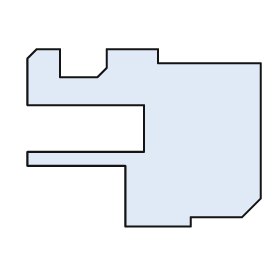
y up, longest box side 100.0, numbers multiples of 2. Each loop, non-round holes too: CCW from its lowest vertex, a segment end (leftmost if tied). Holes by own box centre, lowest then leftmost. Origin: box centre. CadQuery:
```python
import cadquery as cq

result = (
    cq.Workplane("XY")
    .moveTo(-8.0, -38.0)
    .lineTo(20.0, -38.0)
    .lineTo(20.0, -34.0)
    .lineTo(42.0, -34.0)
    .lineTo(50.0, -26.0)
    .lineTo(50.0, 32.0)
    .lineTo(6.0, 32.0)
    .lineTo(6.0, 38.0)
    .lineTo(-16.0, 38.0)
    .lineTo(-16.0, 30.0)
    .lineTo(-20.0, 26.0)
    .lineTo(-36.0, 26.0)
    .lineTo(-36.0, 38.0)
    .lineTo(-46.0, 38.0)
    .lineTo(-50.0, 34.0)
    .lineTo(-50.0, 14.0)
    .lineTo(0.0, 14.0)
    .lineTo(0.0, -6.0)
    .lineTo(-50.0, -6.0)
    .lineTo(-50.0, -12.0)
    .lineTo(-8.0, -12.0)
    .close()
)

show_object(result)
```